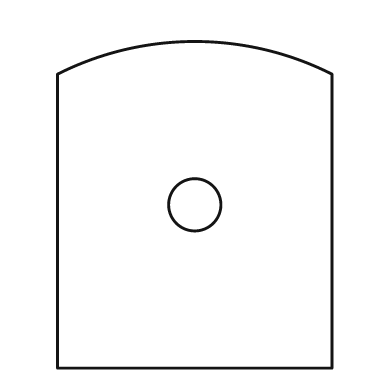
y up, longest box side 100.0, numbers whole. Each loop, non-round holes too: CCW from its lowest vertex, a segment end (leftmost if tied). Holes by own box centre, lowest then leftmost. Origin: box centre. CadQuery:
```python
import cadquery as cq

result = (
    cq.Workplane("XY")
    .moveTo(-42.0, -50.0)
    .lineTo(42.0, -50.0)
    .lineTo(42.0, 40.0)
    .threePointArc((0.0, 50.0), (-42.0, 40.0))
    .close()
    .moveTo(0.0, 0.0)
    .circle(8.0)
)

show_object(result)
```